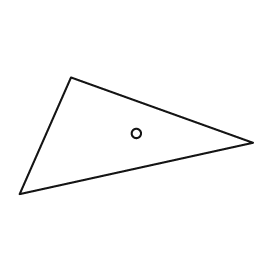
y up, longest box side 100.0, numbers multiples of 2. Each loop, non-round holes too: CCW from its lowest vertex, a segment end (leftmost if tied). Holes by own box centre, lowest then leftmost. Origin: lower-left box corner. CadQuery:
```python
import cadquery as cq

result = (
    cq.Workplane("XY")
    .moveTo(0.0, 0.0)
    .lineTo(100.0, 22.0)
    .lineTo(22.0, 50.0)
    .close()
    .moveTo(50.0, 26.0)
    .circle(2.0)
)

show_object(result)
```